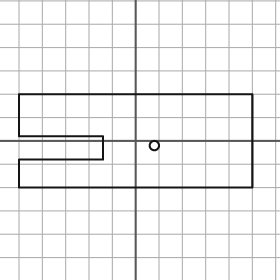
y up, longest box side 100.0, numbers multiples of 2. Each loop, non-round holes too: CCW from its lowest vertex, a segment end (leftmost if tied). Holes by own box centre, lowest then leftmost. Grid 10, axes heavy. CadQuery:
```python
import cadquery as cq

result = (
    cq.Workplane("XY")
    .moveTo(-50.0, -20.0)
    .lineTo(50.0, -20.0)
    .lineTo(50.0, 20.0)
    .lineTo(-50.0, 20.0)
    .lineTo(-50.0, 2.0)
    .lineTo(-14.0, 2.0)
    .lineTo(-14.0, -8.0)
    .lineTo(-50.0, -8.0)
    .close()
    .moveTo(8.0, -2.0)
    .circle(2.0)
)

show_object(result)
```